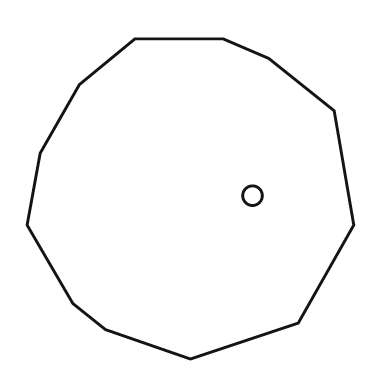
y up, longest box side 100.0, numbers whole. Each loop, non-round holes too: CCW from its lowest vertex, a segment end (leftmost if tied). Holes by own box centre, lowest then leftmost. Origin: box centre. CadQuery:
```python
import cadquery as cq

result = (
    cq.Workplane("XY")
    .moveTo(0.0, -49.0)
    .lineTo(33.0, -38.0)
    .lineTo(50.0, -8.0)
    .lineTo(44.0, 27.0)
    .lineTo(24.0, 43.0)
    .lineTo(10.0, 49.0)
    .lineTo(-17.0, 49.0)
    .lineTo(-34.0, 35.0)
    .lineTo(-46.0, 14.0)
    .lineTo(-50.0, -8.0)
    .lineTo(-36.0, -32.0)
    .lineTo(-26.0, -40.0)
    .close()
    .moveTo(19.0, 1.0)
    .circle(3.0)
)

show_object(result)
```